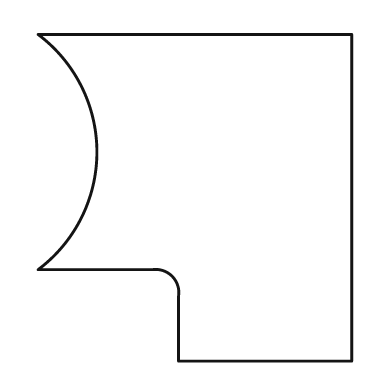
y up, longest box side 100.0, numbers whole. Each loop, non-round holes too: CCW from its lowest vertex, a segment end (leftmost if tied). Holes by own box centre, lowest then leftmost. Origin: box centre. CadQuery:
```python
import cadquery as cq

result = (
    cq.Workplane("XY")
    .moveTo(-5.0, -50.0)
    .lineTo(48.0, -50.0)
    .lineTo(48.0, 50.0)
    .lineTo(-48.0, 50.0)
    .threePointArc((-30.0, 14.0), (-48.0, -22.0))
    .lineTo(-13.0, -22.0)
    .threePointArc((-7.0, -24.0), (-5.0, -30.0))
    .close()
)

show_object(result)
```